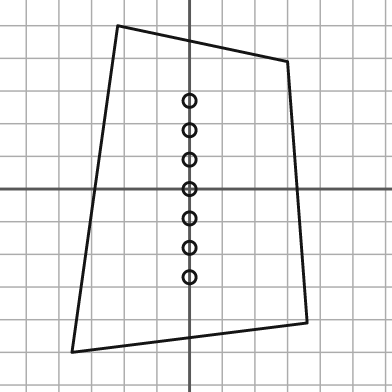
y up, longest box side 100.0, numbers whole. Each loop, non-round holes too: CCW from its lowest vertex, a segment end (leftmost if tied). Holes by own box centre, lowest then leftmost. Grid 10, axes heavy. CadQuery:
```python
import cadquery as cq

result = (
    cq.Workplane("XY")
    .moveTo(-36.0, -50.0)
    .lineTo(36.0, -41.0)
    .lineTo(30.0, 39.0)
    .lineTo(-22.0, 50.0)
    .close()
    .moveTo(0.0, -27.0)
    .circle(2.0)
    .moveTo(0.0, -18.0)
    .circle(2.0)
    .moveTo(0.0, -9.0)
    .circle(2.0)
    .moveTo(0.0, 0.0)
    .circle(2.0)
    .moveTo(0.0, 9.0)
    .circle(2.0)
    .moveTo(0.0, 18.0)
    .circle(2.0)
    .moveTo(0.0, 27.0)
    .circle(2.0)
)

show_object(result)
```